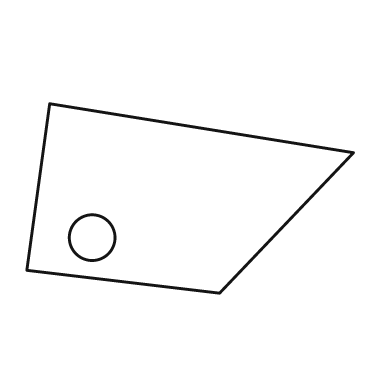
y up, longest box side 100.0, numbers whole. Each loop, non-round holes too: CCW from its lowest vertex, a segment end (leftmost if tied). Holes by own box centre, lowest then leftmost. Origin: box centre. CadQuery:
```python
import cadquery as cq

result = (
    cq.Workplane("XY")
    .moveTo(9.0, -29.0)
    .lineTo(50.0, 14.0)
    .lineTo(-43.0, 29.0)
    .lineTo(-50.0, -22.0)
    .close()
    .moveTo(-30.0, -12.0)
    .circle(7.0)
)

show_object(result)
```